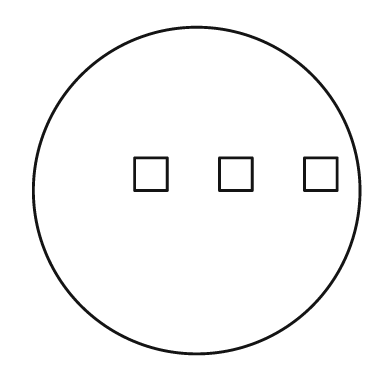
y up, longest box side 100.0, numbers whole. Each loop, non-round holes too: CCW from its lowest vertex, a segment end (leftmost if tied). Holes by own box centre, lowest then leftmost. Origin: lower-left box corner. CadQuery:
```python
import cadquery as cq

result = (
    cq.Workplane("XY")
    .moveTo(50.0, 50.0)
    .circle(50.0)
    .moveTo(31.0, 50.0)
    .lineTo(41.0, 50.0)
    .lineTo(41.0, 60.0)
    .lineTo(31.0, 60.0)
    .close()
    .moveTo(57.0, 50.0)
    .lineTo(67.0, 50.0)
    .lineTo(67.0, 60.0)
    .lineTo(57.0, 60.0)
    .close()
    .moveTo(83.0, 50.0)
    .lineTo(93.0, 50.0)
    .lineTo(93.0, 60.0)
    .lineTo(83.0, 60.0)
    .close()
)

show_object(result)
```